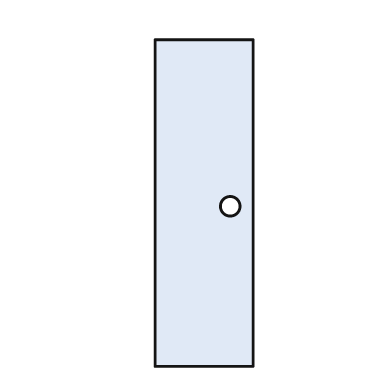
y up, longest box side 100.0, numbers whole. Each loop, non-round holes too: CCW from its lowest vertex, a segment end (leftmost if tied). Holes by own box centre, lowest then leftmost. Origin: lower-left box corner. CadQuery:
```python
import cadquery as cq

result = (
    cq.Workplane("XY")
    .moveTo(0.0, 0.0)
    .lineTo(30.0, 0.0)
    .lineTo(30.0, 100.0)
    .lineTo(0.0, 100.0)
    .close()
    .moveTo(23.0, 49.0)
    .circle(3.0)
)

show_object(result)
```